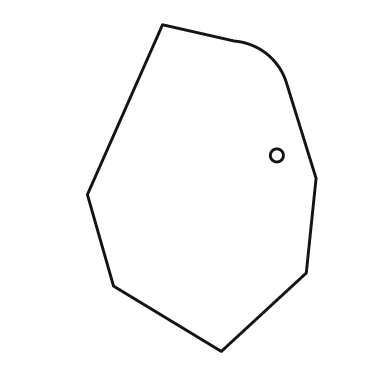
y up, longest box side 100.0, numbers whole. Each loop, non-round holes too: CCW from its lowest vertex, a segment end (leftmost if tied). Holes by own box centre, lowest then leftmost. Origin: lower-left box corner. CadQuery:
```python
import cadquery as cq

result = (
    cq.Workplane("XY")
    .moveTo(41.0, 0.0)
    .lineTo(67.0, 24.0)
    .lineTo(70.0, 53.0)
    .lineTo(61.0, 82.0)
    .threePointArc((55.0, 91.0), (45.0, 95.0))
    .lineTo(23.0, 100.0)
    .lineTo(0.0, 48.0)
    .lineTo(8.0, 20.0)
    .close()
    .moveTo(58.0, 60.0)
    .circle(2.0)
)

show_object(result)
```